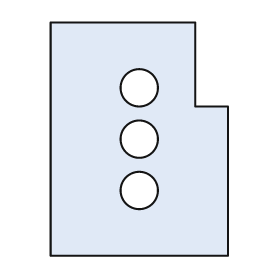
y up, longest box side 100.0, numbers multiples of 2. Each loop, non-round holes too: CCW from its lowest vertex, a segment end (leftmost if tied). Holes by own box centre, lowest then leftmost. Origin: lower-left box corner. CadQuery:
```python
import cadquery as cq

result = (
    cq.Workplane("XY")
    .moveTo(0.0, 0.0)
    .lineTo(76.0, 0.0)
    .lineTo(76.0, 64.0)
    .lineTo(62.0, 64.0)
    .lineTo(62.0, 100.0)
    .lineTo(0.0, 100.0)
    .close()
    .moveTo(38.0, 28.0)
    .circle(8.0)
    .moveTo(38.0, 50.0)
    .circle(8.0)
    .moveTo(38.0, 72.0)
    .circle(8.0)
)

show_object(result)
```